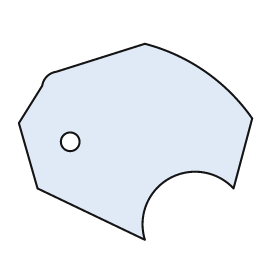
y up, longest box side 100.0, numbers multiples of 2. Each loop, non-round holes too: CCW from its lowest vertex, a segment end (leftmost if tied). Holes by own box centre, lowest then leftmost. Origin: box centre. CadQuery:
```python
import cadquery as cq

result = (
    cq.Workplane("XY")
    .moveTo(4.0, -42.0)
    .threePointArc((14.0, -16.0), (42.0, -20.0))
    .lineTo(50.0, 10.0)
    .threePointArc((30.0, 30.0), (4.0, 42.0))
    .lineTo(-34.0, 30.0)
    .threePointArc((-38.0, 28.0), (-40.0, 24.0))
    .lineTo(-50.0, 8.0)
    .lineTo(-42.0, -20.0)
    .close()
    .moveTo(-28.0, 0.0)
    .circle(4.0)
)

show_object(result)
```